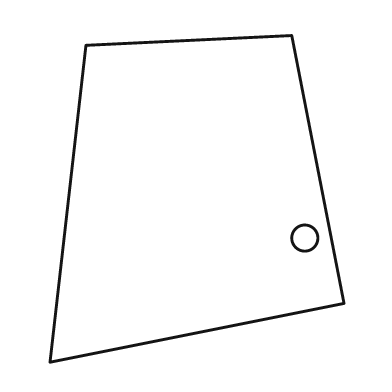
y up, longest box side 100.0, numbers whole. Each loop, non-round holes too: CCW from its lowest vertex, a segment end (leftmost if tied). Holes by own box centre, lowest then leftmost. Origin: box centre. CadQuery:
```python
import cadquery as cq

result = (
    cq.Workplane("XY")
    .moveTo(-45.0, -50.0)
    .lineTo(45.0, -32.0)
    .lineTo(29.0, 50.0)
    .lineTo(-34.0, 47.0)
    .close()
    .moveTo(33.0, -12.0)
    .circle(4.0)
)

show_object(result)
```